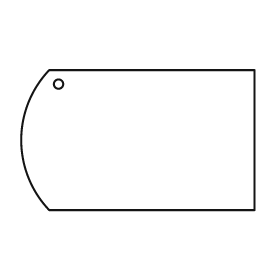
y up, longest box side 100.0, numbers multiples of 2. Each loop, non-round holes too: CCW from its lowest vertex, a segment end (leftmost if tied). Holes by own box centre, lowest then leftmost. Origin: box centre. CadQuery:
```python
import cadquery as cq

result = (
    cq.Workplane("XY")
    .moveTo(-38.0, -30.0)
    .lineTo(50.0, -30.0)
    .lineTo(50.0, 30.0)
    .lineTo(-38.0, 30.0)
    .threePointArc((-50.0, 0.0), (-38.0, -30.0))
    .close()
    .moveTo(-34.0, 24.0)
    .circle(2.0)
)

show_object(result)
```